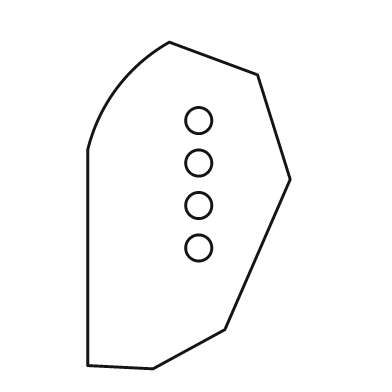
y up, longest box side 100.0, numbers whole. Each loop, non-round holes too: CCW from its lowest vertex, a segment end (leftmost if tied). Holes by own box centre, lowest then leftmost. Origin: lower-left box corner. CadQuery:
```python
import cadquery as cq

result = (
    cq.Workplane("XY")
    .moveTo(20.0, 0.0)
    .lineTo(42.0, 12.0)
    .lineTo(62.0, 58.0)
    .lineTo(52.0, 90.0)
    .lineTo(25.0, 100.0)
    .threePointArc((9.0, 86.0), (0.0, 67.0))
    .lineTo(0.0, 1.0)
    .close()
    .moveTo(34.0, 37.0)
    .circle(4.0)
    .moveTo(34.0, 50.0)
    .circle(4.0)
    .moveTo(34.0, 63.0)
    .circle(4.0)
    .moveTo(34.0, 76.0)
    .circle(4.0)
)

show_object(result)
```